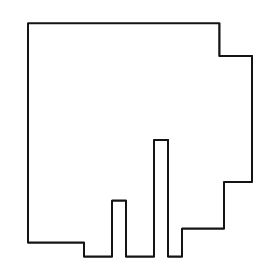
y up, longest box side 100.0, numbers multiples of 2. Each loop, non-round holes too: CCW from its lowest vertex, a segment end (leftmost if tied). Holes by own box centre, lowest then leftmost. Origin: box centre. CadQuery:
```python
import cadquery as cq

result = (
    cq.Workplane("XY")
    .moveTo(-24.0, -50.0)
    .lineTo(-12.0, -50.0)
    .lineTo(-12.0, -26.0)
    .lineTo(-6.0, -26.0)
    .lineTo(-6.0, -50.0)
    .lineTo(6.0, -50.0)
    .lineTo(6.0, 0.0)
    .lineTo(12.0, 0.0)
    .lineTo(12.0, -50.0)
    .lineTo(18.0, -50.0)
    .lineTo(18.0, -38.0)
    .lineTo(36.0, -38.0)
    .lineTo(36.0, -18.0)
    .lineTo(48.0, -18.0)
    .lineTo(48.0, 36.0)
    .lineTo(34.0, 36.0)
    .lineTo(34.0, 50.0)
    .lineTo(-48.0, 50.0)
    .lineTo(-48.0, -44.0)
    .lineTo(-24.0, -44.0)
    .close()
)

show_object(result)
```